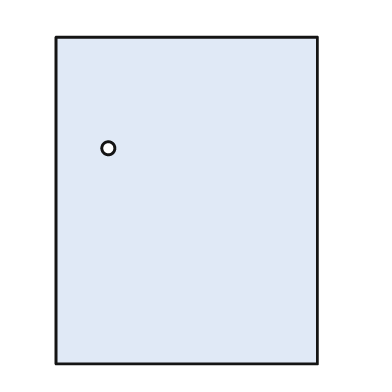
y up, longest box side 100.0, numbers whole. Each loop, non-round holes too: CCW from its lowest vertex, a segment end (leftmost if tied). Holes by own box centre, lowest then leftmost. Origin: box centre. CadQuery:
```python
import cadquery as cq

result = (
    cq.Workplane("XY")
    .moveTo(-40.0, -50.0)
    .lineTo(40.0, -50.0)
    .lineTo(40.0, 50.0)
    .lineTo(-40.0, 50.0)
    .close()
    .moveTo(-24.0, 16.0)
    .circle(2.0)
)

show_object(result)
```